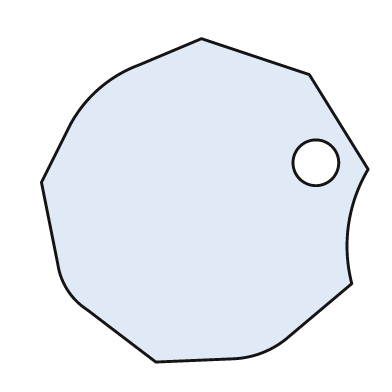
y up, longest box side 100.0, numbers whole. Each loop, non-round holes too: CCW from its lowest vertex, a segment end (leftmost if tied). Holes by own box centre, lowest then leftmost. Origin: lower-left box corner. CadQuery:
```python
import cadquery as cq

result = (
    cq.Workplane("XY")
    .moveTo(35.0, 0.0)
    .lineTo(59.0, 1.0)
    .threePointArc((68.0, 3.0), (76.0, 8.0))
    .lineTo(95.0, 24.0)
    .threePointArc((94.0, 42.0), (100.0, 59.0))
    .lineTo(82.0, 88.0)
    .lineTo(49.0, 99.0)
    .lineTo(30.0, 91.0)
    .threePointArc((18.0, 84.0), (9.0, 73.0))
    .lineTo(0.0, 55.0)
    .lineTo(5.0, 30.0)
    .threePointArc((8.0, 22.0), (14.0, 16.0))
    .close()
    .moveTo(84.0, 61.0)
    .circle(7.0)
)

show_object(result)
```